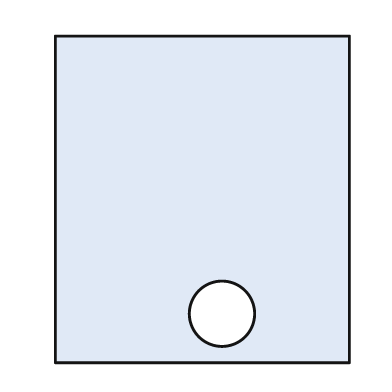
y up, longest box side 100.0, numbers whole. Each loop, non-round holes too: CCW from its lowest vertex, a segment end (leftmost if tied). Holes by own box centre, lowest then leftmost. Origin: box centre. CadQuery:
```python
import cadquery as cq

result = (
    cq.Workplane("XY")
    .moveTo(-45.0, -50.0)
    .lineTo(45.0, -50.0)
    .lineTo(45.0, 50.0)
    .lineTo(-45.0, 50.0)
    .close()
    .moveTo(6.0, -35.0)
    .circle(10.0)
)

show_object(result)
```